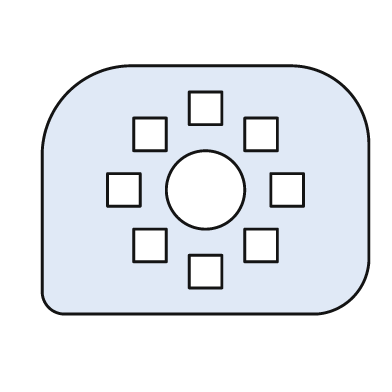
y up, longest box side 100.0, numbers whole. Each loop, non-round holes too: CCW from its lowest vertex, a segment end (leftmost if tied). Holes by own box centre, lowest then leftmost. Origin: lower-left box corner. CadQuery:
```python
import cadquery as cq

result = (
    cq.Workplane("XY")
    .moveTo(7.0, 0.0)
    .lineTo(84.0, 0.0)
    .threePointArc((95.0, 5.0), (100.0, 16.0))
    .lineTo(100.0, 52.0)
    .threePointArc((93.0, 69.0), (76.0, 76.0))
    .lineTo(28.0, 76.0)
    .threePointArc((8.0, 68.0), (0.0, 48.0))
    .lineTo(0.0, 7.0)
    .threePointArc((2.0, 2.0), (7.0, 0.0))
    .close()
    .moveTo(45.0, 8.0)
    .lineTo(55.0, 8.0)
    .lineTo(55.0, 18.0)
    .lineTo(45.0, 18.0)
    .close()
    .moveTo(28.0, 16.0)
    .lineTo(38.0, 16.0)
    .lineTo(38.0, 26.0)
    .lineTo(28.0, 26.0)
    .close()
    .moveTo(62.0, 16.0)
    .lineTo(72.0, 16.0)
    .lineTo(72.0, 26.0)
    .lineTo(62.0, 26.0)
    .close()
    .moveTo(20.0, 33.0)
    .lineTo(30.0, 33.0)
    .lineTo(30.0, 43.0)
    .lineTo(20.0, 43.0)
    .close()
    .moveTo(50.0, 38.0)
    .circle(12.0)
    .moveTo(70.0, 33.0)
    .lineTo(80.0, 33.0)
    .lineTo(80.0, 43.0)
    .lineTo(70.0, 43.0)
    .close()
    .moveTo(28.0, 50.0)
    .lineTo(38.0, 50.0)
    .lineTo(38.0, 60.0)
    .lineTo(28.0, 60.0)
    .close()
    .moveTo(62.0, 50.0)
    .lineTo(72.0, 50.0)
    .lineTo(72.0, 60.0)
    .lineTo(62.0, 60.0)
    .close()
    .moveTo(45.0, 58.0)
    .lineTo(55.0, 58.0)
    .lineTo(55.0, 68.0)
    .lineTo(45.0, 68.0)
    .close()
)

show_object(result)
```